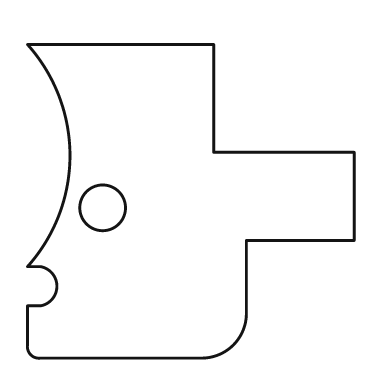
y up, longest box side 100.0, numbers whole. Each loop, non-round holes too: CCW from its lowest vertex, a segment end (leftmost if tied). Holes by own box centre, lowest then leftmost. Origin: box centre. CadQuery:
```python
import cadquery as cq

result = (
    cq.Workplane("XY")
    .moveTo(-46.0, -48.0)
    .lineTo(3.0, -48.0)
    .threePointArc((13.0, -44.0), (17.0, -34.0))
    .lineTo(17.0, -12.0)
    .lineTo(50.0, -12.0)
    .lineTo(50.0, 15.0)
    .lineTo(7.0, 15.0)
    .lineTo(7.0, 48.0)
    .lineTo(-50.0, 48.0)
    .threePointArc((-37.0, 14.0), (-50.0, -20.0))
    .lineTo(-46.0, -20.0)
    .threePointArc((-41.0, -26.0), (-46.0, -32.0))
    .lineTo(-50.0, -32.0)
    .lineTo(-50.0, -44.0)
    .threePointArc((-49.0, -47.0), (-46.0, -48.0))
    .close()
    .moveTo(-27.0, -2.0)
    .circle(7.0)
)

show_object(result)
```